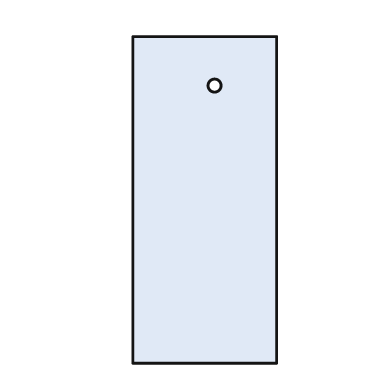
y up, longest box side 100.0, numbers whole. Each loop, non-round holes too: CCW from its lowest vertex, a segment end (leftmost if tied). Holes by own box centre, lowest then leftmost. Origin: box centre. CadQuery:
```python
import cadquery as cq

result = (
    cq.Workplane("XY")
    .moveTo(-22.0, -50.0)
    .lineTo(22.0, -50.0)
    .lineTo(22.0, 50.0)
    .lineTo(-22.0, 50.0)
    .close()
    .moveTo(3.0, 35.0)
    .circle(2.0)
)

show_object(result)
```